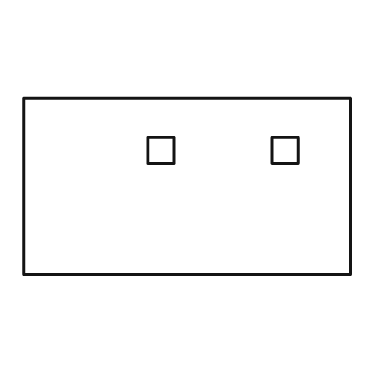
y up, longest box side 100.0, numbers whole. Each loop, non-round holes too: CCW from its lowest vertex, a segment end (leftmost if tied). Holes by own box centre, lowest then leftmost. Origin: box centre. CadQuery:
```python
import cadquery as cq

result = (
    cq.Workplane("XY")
    .moveTo(-50.0, -27.0)
    .lineTo(50.0, -27.0)
    .lineTo(50.0, 27.0)
    .lineTo(-50.0, 27.0)
    .close()
    .moveTo(-12.0, 7.0)
    .lineTo(-4.0, 7.0)
    .lineTo(-4.0, 15.0)
    .lineTo(-12.0, 15.0)
    .close()
    .moveTo(26.0, 7.0)
    .lineTo(34.0, 7.0)
    .lineTo(34.0, 15.0)
    .lineTo(26.0, 15.0)
    .close()
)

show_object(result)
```